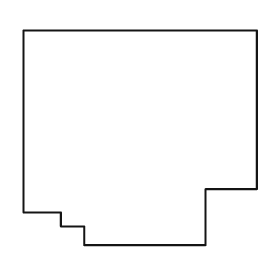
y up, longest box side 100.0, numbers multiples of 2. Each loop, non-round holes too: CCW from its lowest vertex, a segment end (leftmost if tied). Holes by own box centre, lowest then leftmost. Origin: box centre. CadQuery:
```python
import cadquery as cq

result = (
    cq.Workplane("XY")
    .moveTo(-24.0, -46.0)
    .lineTo(28.0, -46.0)
    .lineTo(28.0, -22.0)
    .lineTo(50.0, -22.0)
    .lineTo(50.0, 46.0)
    .lineTo(-50.0, 46.0)
    .lineTo(-50.0, -32.0)
    .lineTo(-34.0, -32.0)
    .lineTo(-34.0, -38.0)
    .lineTo(-24.0, -38.0)
    .close()
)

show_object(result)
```